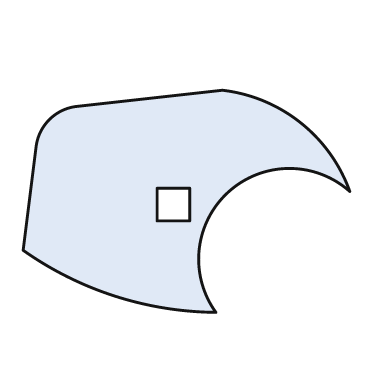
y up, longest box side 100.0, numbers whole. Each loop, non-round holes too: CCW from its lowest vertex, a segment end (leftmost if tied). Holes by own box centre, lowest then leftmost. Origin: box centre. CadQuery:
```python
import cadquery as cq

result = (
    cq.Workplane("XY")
    .moveTo(9.0, -34.0)
    .threePointArc((13.0, 3.0), (50.0, 3.0))
    .threePointArc((35.0, 24.0), (11.0, 34.0))
    .lineTo(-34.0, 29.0)
    .threePointArc((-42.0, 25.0), (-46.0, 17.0))
    .lineTo(-50.0, -15.0)
    .threePointArc((-22.0, -29.0), (9.0, -34.0))
    .close()
    .moveTo(-9.0, -6.0)
    .lineTo(1.0, -6.0)
    .lineTo(1.0, 4.0)
    .lineTo(-9.0, 4.0)
    .close()
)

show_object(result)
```